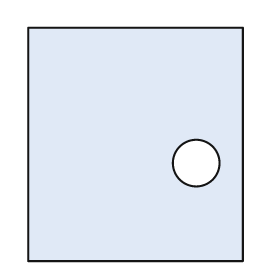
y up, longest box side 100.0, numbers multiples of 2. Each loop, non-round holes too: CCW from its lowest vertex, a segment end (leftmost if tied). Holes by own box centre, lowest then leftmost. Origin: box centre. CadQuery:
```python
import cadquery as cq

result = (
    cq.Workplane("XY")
    .moveTo(-46.0, -50.0)
    .lineTo(46.0, -50.0)
    .lineTo(46.0, 50.0)
    .lineTo(-46.0, 50.0)
    .close()
    .moveTo(26.0, -8.0)
    .circle(10.0)
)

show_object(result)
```